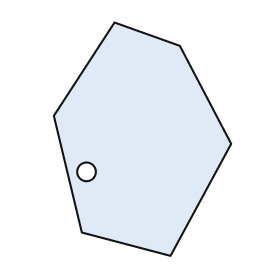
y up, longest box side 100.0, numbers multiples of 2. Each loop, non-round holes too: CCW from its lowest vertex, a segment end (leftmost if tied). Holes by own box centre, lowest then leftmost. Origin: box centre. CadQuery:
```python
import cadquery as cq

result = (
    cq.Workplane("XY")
    .moveTo(12.0, -50.0)
    .lineTo(38.0, -2.0)
    .lineTo(16.0, 40.0)
    .lineTo(-12.0, 50.0)
    .lineTo(-38.0, 10.0)
    .lineTo(-26.0, -40.0)
    .close()
    .moveTo(-24.0, -14.0)
    .circle(4.0)
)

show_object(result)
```